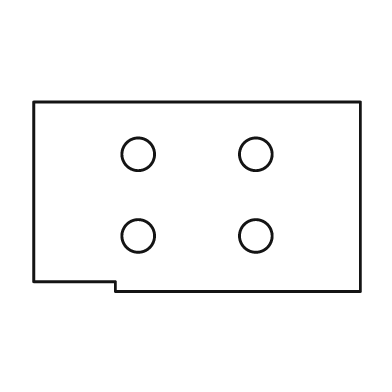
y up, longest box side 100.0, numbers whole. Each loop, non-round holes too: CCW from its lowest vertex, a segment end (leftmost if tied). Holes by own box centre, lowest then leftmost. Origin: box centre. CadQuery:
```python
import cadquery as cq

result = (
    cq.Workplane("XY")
    .moveTo(-25.0, -29.0)
    .lineTo(50.0, -29.0)
    .lineTo(50.0, 29.0)
    .lineTo(-50.0, 29.0)
    .lineTo(-50.0, -26.0)
    .lineTo(-25.0, -26.0)
    .close()
    .moveTo(-18.0, -12.0)
    .circle(5.0)
    .moveTo(18.0, -12.0)
    .circle(5.0)
    .moveTo(-18.0, 13.0)
    .circle(5.0)
    .moveTo(18.0, 13.0)
    .circle(5.0)
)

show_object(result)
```